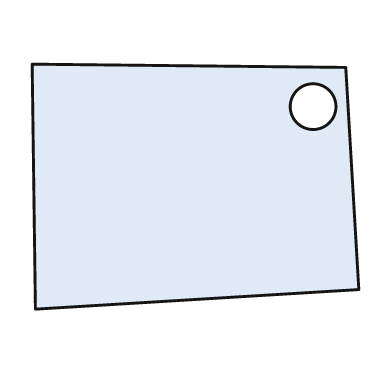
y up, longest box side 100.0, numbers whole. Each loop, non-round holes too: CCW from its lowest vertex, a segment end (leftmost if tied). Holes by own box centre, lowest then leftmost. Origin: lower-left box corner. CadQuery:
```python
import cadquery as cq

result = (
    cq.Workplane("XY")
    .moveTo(1.0, 0.0)
    .lineTo(100.0, 6.0)
    .lineTo(96.0, 74.0)
    .lineTo(0.0, 75.0)
    .close()
    .moveTo(86.0, 62.0)
    .circle(7.0)
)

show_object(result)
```